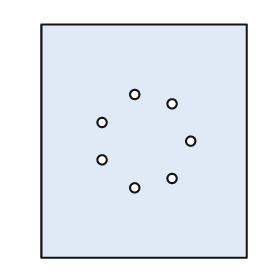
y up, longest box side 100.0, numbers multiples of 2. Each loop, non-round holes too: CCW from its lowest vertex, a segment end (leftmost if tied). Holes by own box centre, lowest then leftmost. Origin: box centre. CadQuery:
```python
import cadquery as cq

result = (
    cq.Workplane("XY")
    .moveTo(-44.0, -50.0)
    .lineTo(44.0, -50.0)
    .lineTo(44.0, 50.0)
    .lineTo(-44.0, 50.0)
    .close()
    .moveTo(-4.0, -20.0)
    .circle(2.0)
    .moveTo(12.0, -16.0)
    .circle(2.0)
    .moveTo(-18.0, -8.0)
    .circle(2.0)
    .moveTo(20.0, 0.0)
    .circle(2.0)
    .moveTo(-18.0, 8.0)
    .circle(2.0)
    .moveTo(12.0, 16.0)
    .circle(2.0)
    .moveTo(-4.0, 20.0)
    .circle(2.0)
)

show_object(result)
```